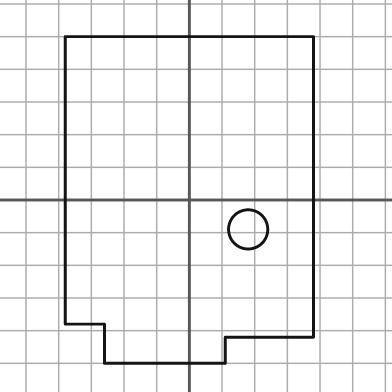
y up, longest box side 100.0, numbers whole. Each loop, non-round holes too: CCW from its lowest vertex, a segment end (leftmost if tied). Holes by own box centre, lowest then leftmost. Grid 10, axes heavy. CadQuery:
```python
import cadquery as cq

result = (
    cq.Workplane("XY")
    .moveTo(-26.0, -50.0)
    .lineTo(11.0, -50.0)
    .lineTo(11.0, -42.0)
    .lineTo(38.0, -42.0)
    .lineTo(38.0, 50.0)
    .lineTo(-38.0, 50.0)
    .lineTo(-38.0, -38.0)
    .lineTo(-26.0, -38.0)
    .close()
    .moveTo(18.0, -9.0)
    .circle(6.0)
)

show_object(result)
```